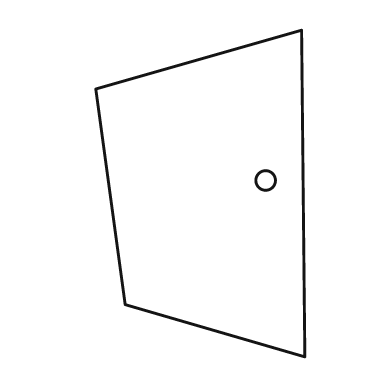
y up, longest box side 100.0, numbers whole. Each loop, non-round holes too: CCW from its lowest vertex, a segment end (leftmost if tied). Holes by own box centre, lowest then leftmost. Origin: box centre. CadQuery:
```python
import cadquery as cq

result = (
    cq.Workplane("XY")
    .moveTo(32.0, -50.0)
    .lineTo(31.0, 50.0)
    .lineTo(-32.0, 32.0)
    .lineTo(-23.0, -34.0)
    .close()
    .moveTo(20.0, 4.0)
    .circle(3.0)
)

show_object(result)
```